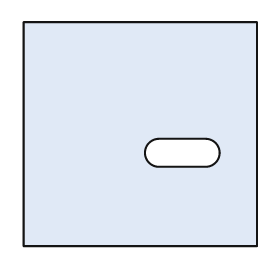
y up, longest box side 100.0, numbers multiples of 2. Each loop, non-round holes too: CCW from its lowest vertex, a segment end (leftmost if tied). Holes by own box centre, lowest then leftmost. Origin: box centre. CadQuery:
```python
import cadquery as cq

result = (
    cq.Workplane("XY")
    .moveTo(-50.0, -48.0)
    .lineTo(50.0, -48.0)
    .lineTo(50.0, 48.0)
    .lineTo(-50.0, 48.0)
    .close()
    .moveTo(8.0, -14.0)
    .lineTo(28.0, -14.0)
    .threePointArc((34.0, -8.0), (28.0, -2.0))
    .lineTo(8.0, -2.0)
    .threePointArc((2.0, -8.0), (8.0, -14.0))
    .close()
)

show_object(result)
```